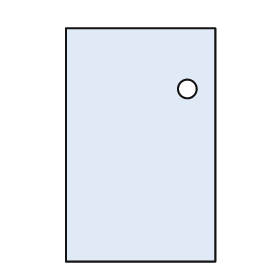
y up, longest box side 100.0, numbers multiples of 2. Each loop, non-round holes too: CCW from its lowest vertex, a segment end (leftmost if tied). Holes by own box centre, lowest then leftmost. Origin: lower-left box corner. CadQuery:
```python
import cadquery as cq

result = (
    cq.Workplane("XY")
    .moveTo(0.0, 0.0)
    .lineTo(64.0, 0.0)
    .lineTo(64.0, 100.0)
    .lineTo(0.0, 100.0)
    .close()
    .moveTo(52.0, 74.0)
    .circle(4.0)
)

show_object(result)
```